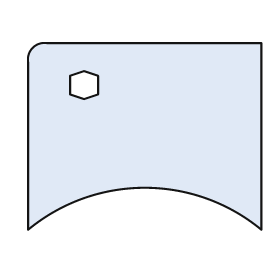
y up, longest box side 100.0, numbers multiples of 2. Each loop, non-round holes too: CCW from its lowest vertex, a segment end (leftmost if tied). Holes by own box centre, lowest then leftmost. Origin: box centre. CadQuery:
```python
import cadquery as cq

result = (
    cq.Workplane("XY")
    .moveTo(-50.0, -40.0)
    .threePointArc((0.0, -22.0), (50.0, -40.0))
    .lineTo(50.0, 40.0)
    .lineTo(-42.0, 40.0)
    .threePointArc((-48.0, 38.0), (-50.0, 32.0))
    .close()
    .moveTo(-26.0, 16.0)
    .lineTo(-20.0, 18.0)
    .lineTo(-20.0, 26.0)
    .lineTo(-26.0, 28.0)
    .lineTo(-32.0, 26.0)
    .lineTo(-32.0, 18.0)
    .close()
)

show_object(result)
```